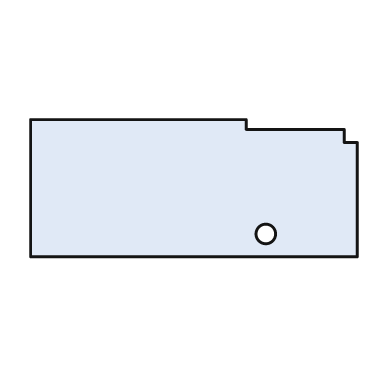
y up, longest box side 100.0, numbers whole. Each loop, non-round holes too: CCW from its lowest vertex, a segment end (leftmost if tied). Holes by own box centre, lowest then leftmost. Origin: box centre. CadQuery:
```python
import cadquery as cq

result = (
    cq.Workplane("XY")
    .moveTo(-50.0, -21.0)
    .lineTo(50.0, -21.0)
    .lineTo(50.0, 14.0)
    .lineTo(46.0, 14.0)
    .lineTo(46.0, 18.0)
    .lineTo(16.0, 18.0)
    .lineTo(16.0, 21.0)
    .lineTo(-50.0, 21.0)
    .close()
    .moveTo(22.0, -14.0)
    .circle(3.0)
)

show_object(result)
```